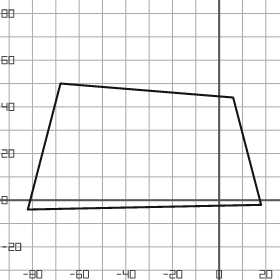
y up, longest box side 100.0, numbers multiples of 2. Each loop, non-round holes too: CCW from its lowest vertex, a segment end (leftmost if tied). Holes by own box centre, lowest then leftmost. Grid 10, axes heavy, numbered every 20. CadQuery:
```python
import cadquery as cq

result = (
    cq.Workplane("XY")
    .moveTo(-82.0, -4.0)
    .lineTo(18.0, -2.0)
    .lineTo(6.0, 44.0)
    .lineTo(-68.0, 50.0)
    .close()
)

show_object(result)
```